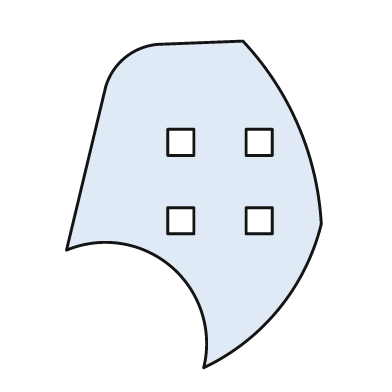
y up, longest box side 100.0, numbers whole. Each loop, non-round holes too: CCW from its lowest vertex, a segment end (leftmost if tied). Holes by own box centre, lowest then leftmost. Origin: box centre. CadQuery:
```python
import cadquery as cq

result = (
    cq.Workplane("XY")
    .moveTo(3.0, -50.0)
    .threePointArc((26.0, -32.0), (39.0, -6.0))
    .threePointArc((32.0, 24.0), (15.0, 50.0))
    .lineTo(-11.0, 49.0)
    .threePointArc((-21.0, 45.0), (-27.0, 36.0))
    .lineTo(-39.0, -14.0)
    .threePointArc((-7.0, -19.0), (3.0, -50.0))
    .close()
    .moveTo(-8.0, -9.0)
    .lineTo(0.0, -9.0)
    .lineTo(0.0, -1.0)
    .lineTo(-8.0, -1.0)
    .close()
    .moveTo(16.0, -9.0)
    .lineTo(24.0, -9.0)
    .lineTo(24.0, -1.0)
    .lineTo(16.0, -1.0)
    .close()
    .moveTo(-8.0, 15.0)
    .lineTo(0.0, 15.0)
    .lineTo(0.0, 23.0)
    .lineTo(-8.0, 23.0)
    .close()
    .moveTo(16.0, 15.0)
    .lineTo(24.0, 15.0)
    .lineTo(24.0, 23.0)
    .lineTo(16.0, 23.0)
    .close()
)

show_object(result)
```